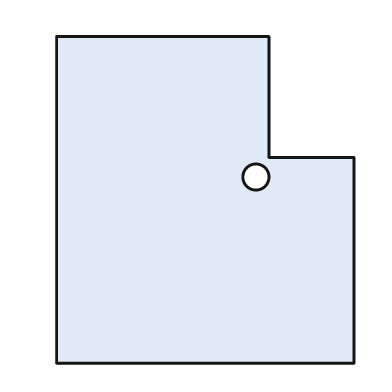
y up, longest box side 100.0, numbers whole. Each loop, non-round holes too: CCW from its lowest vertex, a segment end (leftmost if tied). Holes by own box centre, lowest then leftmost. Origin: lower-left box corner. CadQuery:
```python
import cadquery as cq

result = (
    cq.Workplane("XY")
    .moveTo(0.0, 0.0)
    .lineTo(91.0, 0.0)
    .lineTo(91.0, 63.0)
    .lineTo(65.0, 63.0)
    .lineTo(65.0, 100.0)
    .lineTo(0.0, 100.0)
    .close()
    .moveTo(61.0, 57.0)
    .circle(4.0)
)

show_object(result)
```